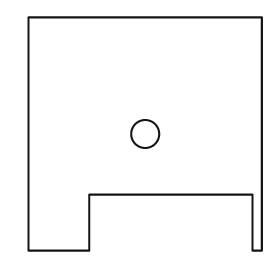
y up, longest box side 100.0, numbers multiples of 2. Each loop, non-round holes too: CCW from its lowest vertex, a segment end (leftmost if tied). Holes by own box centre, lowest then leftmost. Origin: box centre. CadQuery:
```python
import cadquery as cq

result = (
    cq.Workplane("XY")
    .moveTo(-50.0, -50.0)
    .lineTo(-24.0, -50.0)
    .lineTo(-24.0, -26.0)
    .lineTo(46.0, -26.0)
    .lineTo(46.0, -50.0)
    .lineTo(50.0, -50.0)
    .lineTo(50.0, 50.0)
    .lineTo(-50.0, 50.0)
    .close()
    .moveTo(0.0, 0.0)
    .circle(6.0)
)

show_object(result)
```